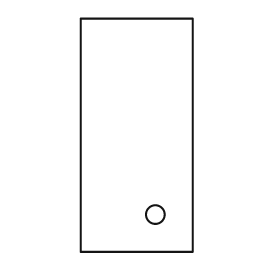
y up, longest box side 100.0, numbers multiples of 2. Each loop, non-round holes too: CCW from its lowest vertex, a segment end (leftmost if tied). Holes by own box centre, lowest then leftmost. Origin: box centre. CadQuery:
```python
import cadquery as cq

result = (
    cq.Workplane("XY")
    .moveTo(-24.0, -50.0)
    .lineTo(24.0, -50.0)
    .lineTo(24.0, 50.0)
    .lineTo(-24.0, 50.0)
    .close()
    .moveTo(8.0, -34.0)
    .circle(4.0)
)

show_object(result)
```